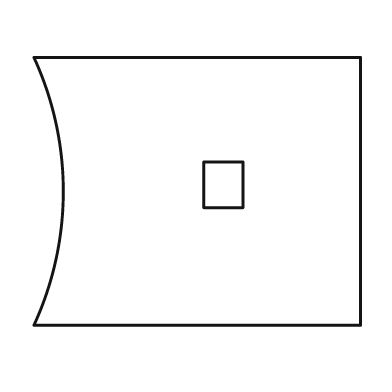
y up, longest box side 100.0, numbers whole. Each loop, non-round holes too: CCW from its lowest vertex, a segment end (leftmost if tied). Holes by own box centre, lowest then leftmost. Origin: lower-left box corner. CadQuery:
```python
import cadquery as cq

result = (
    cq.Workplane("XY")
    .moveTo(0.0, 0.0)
    .lineTo(100.0, 0.0)
    .lineTo(100.0, 82.0)
    .lineTo(0.0, 82.0)
    .threePointArc((9.0, 41.0), (0.0, 0.0))
    .close()
    .moveTo(52.0, 36.0)
    .lineTo(64.0, 36.0)
    .lineTo(64.0, 50.0)
    .lineTo(52.0, 50.0)
    .close()
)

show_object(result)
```